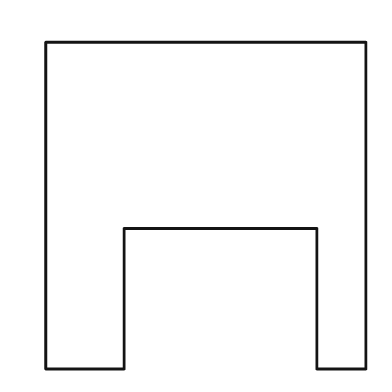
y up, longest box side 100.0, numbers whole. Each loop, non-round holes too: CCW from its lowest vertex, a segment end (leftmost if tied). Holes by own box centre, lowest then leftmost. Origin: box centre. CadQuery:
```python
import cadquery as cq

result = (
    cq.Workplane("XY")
    .moveTo(-49.0, -50.0)
    .lineTo(-25.0, -50.0)
    .lineTo(-25.0, -7.0)
    .lineTo(34.0, -7.0)
    .lineTo(34.0, -50.0)
    .lineTo(49.0, -50.0)
    .lineTo(49.0, 50.0)
    .lineTo(-49.0, 50.0)
    .close()
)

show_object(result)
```